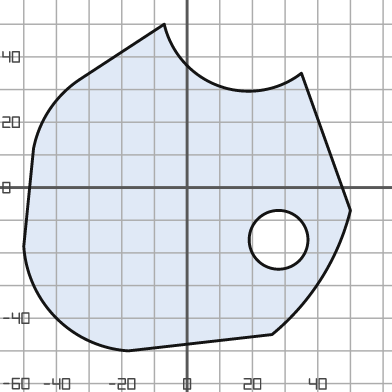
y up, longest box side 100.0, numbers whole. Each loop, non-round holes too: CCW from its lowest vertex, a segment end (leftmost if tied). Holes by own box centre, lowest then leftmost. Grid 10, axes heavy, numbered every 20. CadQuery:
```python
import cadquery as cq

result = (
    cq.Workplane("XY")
    .moveTo(-18.0, -50.0)
    .lineTo(26.0, -45.0)
    .threePointArc((41.0, -28.0), (50.0, -7.0))
    .lineTo(35.0, 35.0)
    .threePointArc((10.0, 31.0), (-7.0, 50.0))
    .lineTo(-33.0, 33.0)
    .threePointArc((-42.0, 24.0), (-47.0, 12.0))
    .lineTo(-50.0, -18.0)
    .threePointArc((-40.0, -40.0), (-18.0, -50.0))
    .close()
    .moveTo(28.0, -16.0)
    .circle(9.0)
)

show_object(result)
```